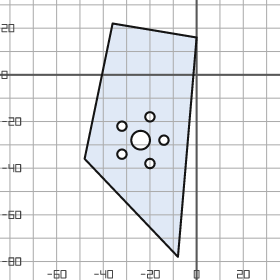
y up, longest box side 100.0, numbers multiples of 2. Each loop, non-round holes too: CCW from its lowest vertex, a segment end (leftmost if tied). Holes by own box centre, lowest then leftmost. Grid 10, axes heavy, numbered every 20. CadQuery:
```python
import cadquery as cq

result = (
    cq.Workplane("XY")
    .moveTo(-8.0, -78.0)
    .lineTo(0.0, 16.0)
    .lineTo(-36.0, 22.0)
    .lineTo(-48.0, -36.0)
    .close()
    .moveTo(-20.0, -38.0)
    .circle(2.0)
    .moveTo(-32.0, -34.0)
    .circle(2.0)
    .moveTo(-24.0, -28.0)
    .circle(4.0)
    .moveTo(-14.0, -28.0)
    .circle(2.0)
    .moveTo(-32.0, -22.0)
    .circle(2.0)
    .moveTo(-20.0, -18.0)
    .circle(2.0)
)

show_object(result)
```